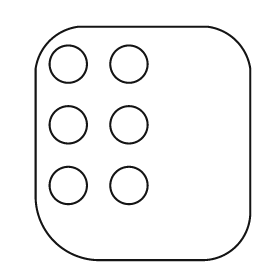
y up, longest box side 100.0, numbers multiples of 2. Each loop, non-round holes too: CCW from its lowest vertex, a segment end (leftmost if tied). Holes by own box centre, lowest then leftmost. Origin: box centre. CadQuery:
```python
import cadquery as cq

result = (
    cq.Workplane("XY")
    .moveTo(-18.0, -50.0)
    .lineTo(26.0, -50.0)
    .threePointArc((40.0, -44.0), (46.0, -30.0))
    .lineTo(46.0, 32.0)
    .threePointArc((40.0, 44.0), (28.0, 50.0))
    .lineTo(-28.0, 50.0)
    .threePointArc((-40.0, 44.0), (-46.0, 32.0))
    .lineTo(-46.0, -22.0)
    .threePointArc((-38.0, -42.0), (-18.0, -50.0))
    .close()
    .moveTo(-32.0, -18.0)
    .circle(8.0)
    .moveTo(-6.0, -18.0)
    .circle(8.0)
    .moveTo(-32.0, 8.0)
    .circle(8.0)
    .moveTo(-6.0, 8.0)
    .circle(8.0)
    .moveTo(-32.0, 34.0)
    .circle(8.0)
    .moveTo(-6.0, 34.0)
    .circle(8.0)
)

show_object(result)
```